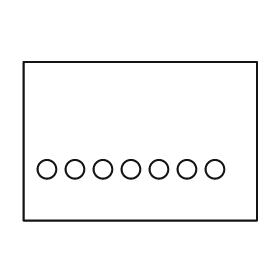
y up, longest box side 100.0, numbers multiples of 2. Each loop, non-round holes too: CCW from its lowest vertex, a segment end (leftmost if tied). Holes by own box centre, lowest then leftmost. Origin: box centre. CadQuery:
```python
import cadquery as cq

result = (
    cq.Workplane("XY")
    .moveTo(-50.0, -34.0)
    .lineTo(50.0, -34.0)
    .lineTo(50.0, 34.0)
    .lineTo(-50.0, 34.0)
    .close()
    .moveTo(-40.0, -12.0)
    .circle(4.0)
    .moveTo(-28.0, -12.0)
    .circle(4.0)
    .moveTo(-16.0, -12.0)
    .circle(4.0)
    .moveTo(-4.0, -12.0)
    .circle(4.0)
    .moveTo(8.0, -12.0)
    .circle(4.0)
    .moveTo(20.0, -12.0)
    .circle(4.0)
    .moveTo(32.0, -12.0)
    .circle(4.0)
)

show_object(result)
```